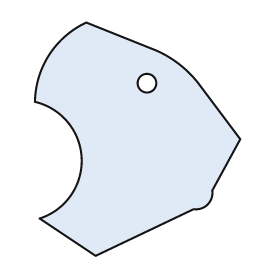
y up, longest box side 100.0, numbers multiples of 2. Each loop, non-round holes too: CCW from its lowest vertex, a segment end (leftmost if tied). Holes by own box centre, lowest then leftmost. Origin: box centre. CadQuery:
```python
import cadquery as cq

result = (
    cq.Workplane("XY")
    .moveTo(-18.0, -50.0)
    .lineTo(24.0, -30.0)
    .threePointArc((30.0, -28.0), (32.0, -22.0))
    .lineTo(44.0, 0.0)
    .lineTo(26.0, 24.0)
    .threePointArc((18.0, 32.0), (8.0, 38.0))
    .lineTo(-22.0, 50.0)
    .threePointArc((-38.0, 36.0), (-44.0, 16.0))
    .threePointArc((-24.0, -8.0), (-42.0, -34.0))
    .close()
    .moveTo(4.0, 24.0)
    .circle(4.0)
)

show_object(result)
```